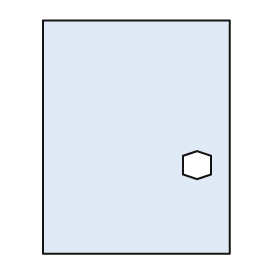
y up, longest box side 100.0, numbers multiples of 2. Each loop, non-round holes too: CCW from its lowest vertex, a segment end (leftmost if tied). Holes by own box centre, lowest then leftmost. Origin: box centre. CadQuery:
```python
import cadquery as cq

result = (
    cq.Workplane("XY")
    .moveTo(-40.0, -50.0)
    .lineTo(40.0, -50.0)
    .lineTo(40.0, 50.0)
    .lineTo(-40.0, 50.0)
    .close()
    .moveTo(26.0, -18.0)
    .lineTo(32.0, -16.0)
    .lineTo(32.0, -8.0)
    .lineTo(26.0, -6.0)
    .lineTo(20.0, -8.0)
    .lineTo(20.0, -16.0)
    .close()
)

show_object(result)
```